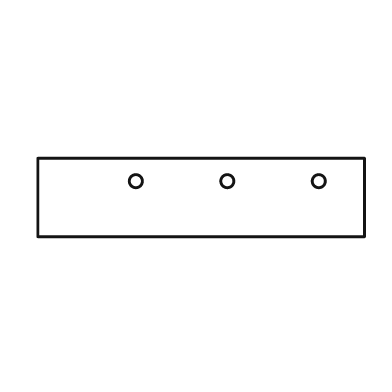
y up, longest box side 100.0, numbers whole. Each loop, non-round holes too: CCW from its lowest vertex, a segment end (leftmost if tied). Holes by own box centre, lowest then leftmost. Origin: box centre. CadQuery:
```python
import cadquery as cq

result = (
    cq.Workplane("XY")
    .moveTo(-50.0, -12.0)
    .lineTo(50.0, -12.0)
    .lineTo(50.0, 12.0)
    .lineTo(-50.0, 12.0)
    .close()
    .moveTo(-20.0, 5.0)
    .circle(2.0)
    .moveTo(8.0, 5.0)
    .circle(2.0)
    .moveTo(36.0, 5.0)
    .circle(2.0)
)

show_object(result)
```